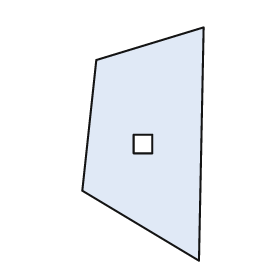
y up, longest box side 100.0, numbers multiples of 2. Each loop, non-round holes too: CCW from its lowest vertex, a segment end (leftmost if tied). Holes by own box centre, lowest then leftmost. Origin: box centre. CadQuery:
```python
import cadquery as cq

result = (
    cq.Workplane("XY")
    .moveTo(24.0, -50.0)
    .lineTo(26.0, 50.0)
    .lineTo(-20.0, 36.0)
    .lineTo(-26.0, -20.0)
    .close()
    .moveTo(-4.0, -4.0)
    .lineTo(4.0, -4.0)
    .lineTo(4.0, 4.0)
    .lineTo(-4.0, 4.0)
    .close()
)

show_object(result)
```